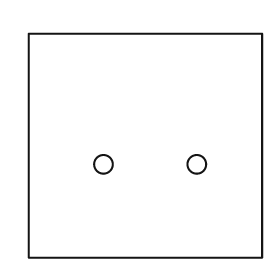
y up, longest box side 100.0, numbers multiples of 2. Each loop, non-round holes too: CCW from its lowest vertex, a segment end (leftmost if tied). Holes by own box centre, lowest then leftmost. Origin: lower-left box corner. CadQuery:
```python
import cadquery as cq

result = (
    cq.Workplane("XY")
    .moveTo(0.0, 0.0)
    .lineTo(100.0, 0.0)
    .lineTo(100.0, 96.0)
    .lineTo(0.0, 96.0)
    .close()
    .moveTo(32.0, 40.0)
    .circle(4.0)
    .moveTo(72.0, 40.0)
    .circle(4.0)
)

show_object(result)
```